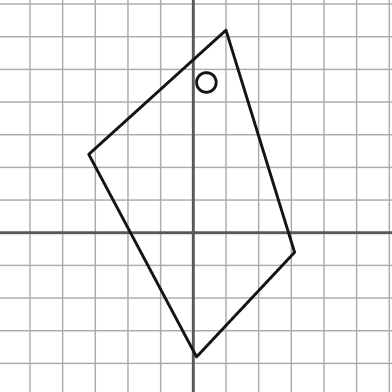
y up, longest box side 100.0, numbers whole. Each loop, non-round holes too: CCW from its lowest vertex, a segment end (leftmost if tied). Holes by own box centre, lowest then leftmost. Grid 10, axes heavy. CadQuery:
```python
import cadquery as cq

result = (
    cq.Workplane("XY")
    .moveTo(1.0, -38.0)
    .lineTo(31.0, -6.0)
    .lineTo(10.0, 62.0)
    .lineTo(-32.0, 24.0)
    .close()
    .moveTo(4.0, 46.0)
    .circle(3.0)
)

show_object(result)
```